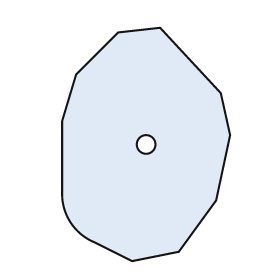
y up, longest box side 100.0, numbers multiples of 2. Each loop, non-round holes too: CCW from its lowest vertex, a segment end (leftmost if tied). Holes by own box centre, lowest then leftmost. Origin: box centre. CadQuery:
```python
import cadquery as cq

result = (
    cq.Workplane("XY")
    .moveTo(-6.0, -50.0)
    .lineTo(14.0, -46.0)
    .lineTo(30.0, -24.0)
    .lineTo(36.0, 4.0)
    .lineTo(32.0, 22.0)
    .lineTo(6.0, 50.0)
    .lineTo(-12.0, 48.0)
    .lineTo(-30.0, 30.0)
    .lineTo(-36.0, 10.0)
    .lineTo(-36.0, -22.0)
    .threePointArc((-32.0, -34.0), (-22.0, -42.0))
    .close()
    .moveTo(0.0, 0.0)
    .circle(4.0)
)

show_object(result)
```